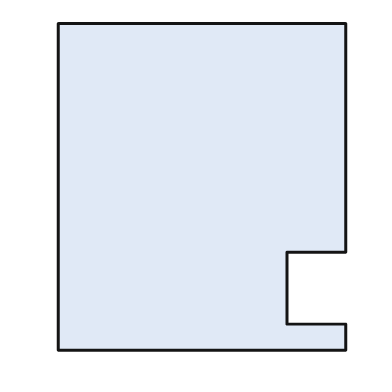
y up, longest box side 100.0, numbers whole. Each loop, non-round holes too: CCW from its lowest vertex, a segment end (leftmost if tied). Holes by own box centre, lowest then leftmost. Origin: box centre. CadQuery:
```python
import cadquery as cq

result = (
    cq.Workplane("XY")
    .moveTo(-44.0, -50.0)
    .lineTo(44.0, -50.0)
    .lineTo(44.0, -42.0)
    .lineTo(26.0, -42.0)
    .lineTo(26.0, -20.0)
    .lineTo(44.0, -20.0)
    .lineTo(44.0, 50.0)
    .lineTo(-44.0, 50.0)
    .close()
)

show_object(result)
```